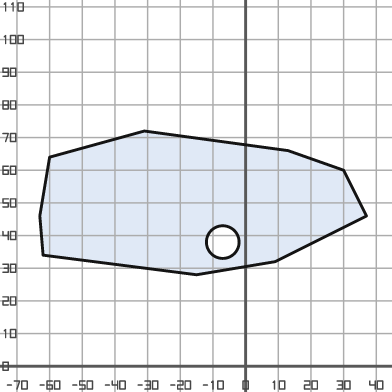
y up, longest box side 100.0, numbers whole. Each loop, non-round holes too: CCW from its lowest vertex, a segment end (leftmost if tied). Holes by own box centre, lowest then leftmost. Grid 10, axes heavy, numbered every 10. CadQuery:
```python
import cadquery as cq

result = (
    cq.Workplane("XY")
    .moveTo(-15.0, 28.0)
    .lineTo(9.0, 32.0)
    .lineTo(37.0, 46.0)
    .lineTo(30.0, 60.0)
    .lineTo(13.0, 66.0)
    .lineTo(-31.0, 72.0)
    .lineTo(-60.0, 64.0)
    .lineTo(-63.0, 46.0)
    .lineTo(-62.0, 34.0)
    .close()
    .moveTo(-7.0, 38.0)
    .circle(5.0)
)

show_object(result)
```